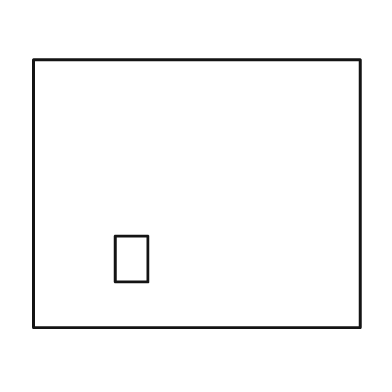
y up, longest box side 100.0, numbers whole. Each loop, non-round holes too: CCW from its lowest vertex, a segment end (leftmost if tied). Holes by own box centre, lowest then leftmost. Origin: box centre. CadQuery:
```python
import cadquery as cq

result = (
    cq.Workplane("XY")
    .moveTo(-50.0, -41.0)
    .lineTo(50.0, -41.0)
    .lineTo(50.0, 41.0)
    .lineTo(-50.0, 41.0)
    .close()
    .moveTo(-25.0, -27.0)
    .lineTo(-15.0, -27.0)
    .lineTo(-15.0, -13.0)
    .lineTo(-25.0, -13.0)
    .close()
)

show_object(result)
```